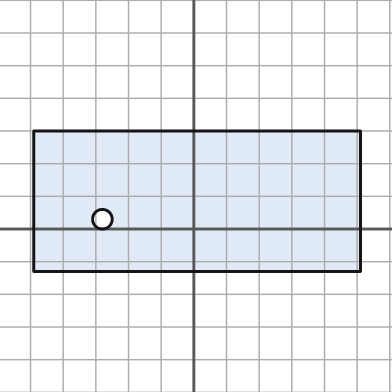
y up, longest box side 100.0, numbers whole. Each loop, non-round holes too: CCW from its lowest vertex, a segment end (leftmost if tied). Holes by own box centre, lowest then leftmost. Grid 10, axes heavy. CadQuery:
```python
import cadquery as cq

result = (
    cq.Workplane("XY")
    .moveTo(-49.0, -13.0)
    .lineTo(51.0, -13.0)
    .lineTo(51.0, 30.0)
    .lineTo(-49.0, 30.0)
    .close()
    .moveTo(-28.0, 3.0)
    .circle(3.0)
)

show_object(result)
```